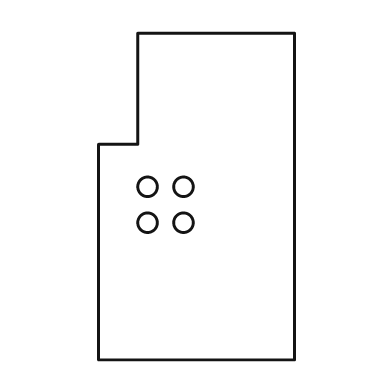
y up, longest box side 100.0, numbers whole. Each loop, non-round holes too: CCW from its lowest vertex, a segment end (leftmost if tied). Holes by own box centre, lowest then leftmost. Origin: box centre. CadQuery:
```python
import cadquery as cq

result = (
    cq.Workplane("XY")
    .moveTo(-30.0, -50.0)
    .lineTo(30.0, -50.0)
    .lineTo(30.0, 50.0)
    .lineTo(-18.0, 50.0)
    .lineTo(-18.0, 16.0)
    .lineTo(-30.0, 16.0)
    .close()
    .moveTo(-15.0, -8.0)
    .circle(3.0)
    .moveTo(-4.0, -8.0)
    .circle(3.0)
    .moveTo(-15.0, 3.0)
    .circle(3.0)
    .moveTo(-4.0, 3.0)
    .circle(3.0)
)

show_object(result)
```